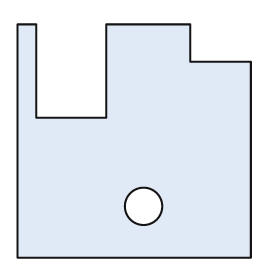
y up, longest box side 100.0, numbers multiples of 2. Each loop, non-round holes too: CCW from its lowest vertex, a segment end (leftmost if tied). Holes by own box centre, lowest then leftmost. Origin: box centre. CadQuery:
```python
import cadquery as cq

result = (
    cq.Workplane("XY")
    .moveTo(-50.0, -50.0)
    .lineTo(50.0, -50.0)
    .lineTo(50.0, 34.0)
    .lineTo(24.0, 34.0)
    .lineTo(24.0, 50.0)
    .lineTo(-12.0, 50.0)
    .lineTo(-12.0, 10.0)
    .lineTo(-42.0, 10.0)
    .lineTo(-42.0, 50.0)
    .lineTo(-50.0, 50.0)
    .close()
    .moveTo(4.0, -28.0)
    .circle(8.0)
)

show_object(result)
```